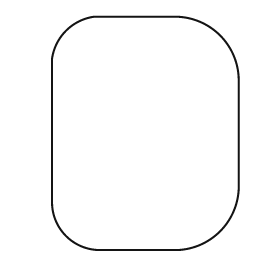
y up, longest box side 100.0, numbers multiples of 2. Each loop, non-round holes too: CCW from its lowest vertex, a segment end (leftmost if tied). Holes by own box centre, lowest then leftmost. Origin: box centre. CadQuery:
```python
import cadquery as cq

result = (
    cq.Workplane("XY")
    .moveTo(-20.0, -50.0)
    .lineTo(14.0, -50.0)
    .threePointArc((32.0, -42.0), (40.0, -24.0))
    .lineTo(40.0, 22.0)
    .threePointArc((32.0, 42.0), (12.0, 50.0))
    .lineTo(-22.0, 50.0)
    .threePointArc((-34.0, 44.0), (-40.0, 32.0))
    .lineTo(-40.0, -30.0)
    .threePointArc((-34.0, -44.0), (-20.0, -50.0))
    .close()
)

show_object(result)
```